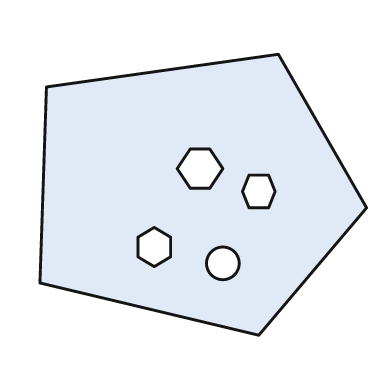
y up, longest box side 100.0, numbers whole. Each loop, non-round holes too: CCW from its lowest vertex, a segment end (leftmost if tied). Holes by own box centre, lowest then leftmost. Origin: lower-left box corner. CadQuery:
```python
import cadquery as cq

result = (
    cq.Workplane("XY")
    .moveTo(67.0, 0.0)
    .lineTo(100.0, 39.0)
    .lineTo(73.0, 86.0)
    .lineTo(2.0, 76.0)
    .lineTo(0.0, 16.0)
    .close()
    .moveTo(56.0, 22.0)
    .circle(5.0)
    .moveTo(35.0, 21.0)
    .lineTo(40.0, 24.0)
    .lineTo(40.0, 30.0)
    .lineTo(35.0, 33.0)
    .lineTo(30.0, 30.0)
    .lineTo(30.0, 24.0)
    .close()
    .moveTo(64.0, 39.0)
    .lineTo(70.0, 39.0)
    .lineTo(72.0, 44.0)
    .lineTo(70.0, 49.0)
    .lineTo(64.0, 49.0)
    .lineTo(62.0, 44.0)
    .close()
    .moveTo(46.0, 45.0)
    .lineTo(52.0, 45.0)
    .lineTo(56.0, 51.0)
    .lineTo(52.0, 57.0)
    .lineTo(46.0, 57.0)
    .lineTo(42.0, 51.0)
    .close()
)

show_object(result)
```